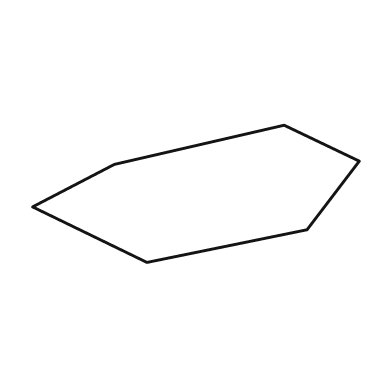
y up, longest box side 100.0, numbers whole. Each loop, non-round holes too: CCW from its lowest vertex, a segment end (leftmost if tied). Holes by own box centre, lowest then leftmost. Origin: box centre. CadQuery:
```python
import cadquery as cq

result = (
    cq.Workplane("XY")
    .moveTo(-15.0, -21.0)
    .lineTo(34.0, -11.0)
    .lineTo(50.0, 10.0)
    .lineTo(27.0, 21.0)
    .lineTo(-25.0, 9.0)
    .lineTo(-50.0, -4.0)
    .close()
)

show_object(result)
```